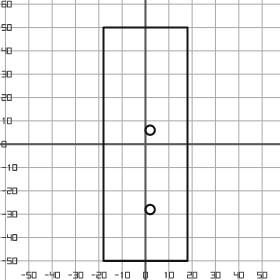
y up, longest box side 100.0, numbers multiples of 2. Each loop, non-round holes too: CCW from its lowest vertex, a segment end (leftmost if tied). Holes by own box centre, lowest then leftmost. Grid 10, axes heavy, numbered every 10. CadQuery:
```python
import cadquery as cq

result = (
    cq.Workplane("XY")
    .moveTo(-18.0, -50.0)
    .lineTo(18.0, -50.0)
    .lineTo(18.0, 50.0)
    .lineTo(-18.0, 50.0)
    .close()
    .moveTo(2.0, -28.0)
    .circle(2.0)
    .moveTo(2.0, 6.0)
    .circle(2.0)
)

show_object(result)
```